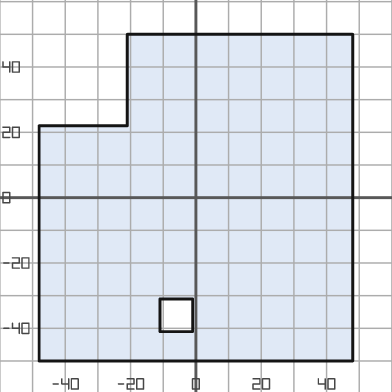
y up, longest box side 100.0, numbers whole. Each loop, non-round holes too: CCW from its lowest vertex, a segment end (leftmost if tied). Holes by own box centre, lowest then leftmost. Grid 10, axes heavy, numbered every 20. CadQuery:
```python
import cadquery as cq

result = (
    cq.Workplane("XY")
    .moveTo(-48.0, -50.0)
    .lineTo(48.0, -50.0)
    .lineTo(48.0, 50.0)
    .lineTo(-21.0, 50.0)
    .lineTo(-21.0, 22.0)
    .lineTo(-48.0, 22.0)
    .close()
    .moveTo(-11.0, -41.0)
    .lineTo(-1.0, -41.0)
    .lineTo(-1.0, -31.0)
    .lineTo(-11.0, -31.0)
    .close()
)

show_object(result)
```